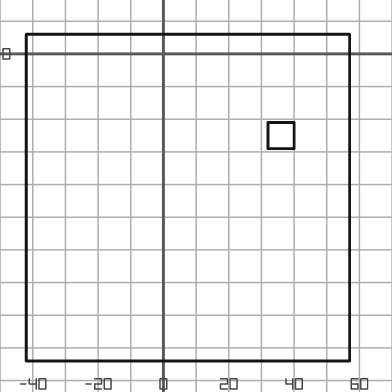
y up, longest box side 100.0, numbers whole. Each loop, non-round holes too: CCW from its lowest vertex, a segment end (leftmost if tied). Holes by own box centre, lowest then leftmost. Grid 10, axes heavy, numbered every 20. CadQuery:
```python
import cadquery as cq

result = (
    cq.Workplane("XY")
    .moveTo(-42.0, -94.0)
    .lineTo(57.0, -94.0)
    .lineTo(57.0, 6.0)
    .lineTo(-42.0, 6.0)
    .close()
    .moveTo(32.0, -29.0)
    .lineTo(40.0, -29.0)
    .lineTo(40.0, -21.0)
    .lineTo(32.0, -21.0)
    .close()
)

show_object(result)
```